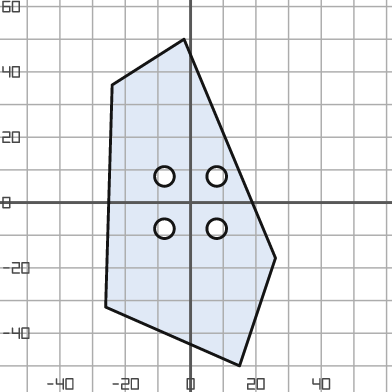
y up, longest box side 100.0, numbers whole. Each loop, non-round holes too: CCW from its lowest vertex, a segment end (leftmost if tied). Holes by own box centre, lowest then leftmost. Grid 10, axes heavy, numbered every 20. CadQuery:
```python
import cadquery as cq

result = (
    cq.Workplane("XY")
    .moveTo(15.0, -50.0)
    .lineTo(26.0, -17.0)
    .lineTo(-2.0, 50.0)
    .lineTo(-24.0, 36.0)
    .lineTo(-26.0, -32.0)
    .close()
    .moveTo(-8.0, -8.0)
    .circle(3.0)
    .moveTo(8.0, -8.0)
    .circle(3.0)
    .moveTo(-8.0, 8.0)
    .circle(3.0)
    .moveTo(8.0, 8.0)
    .circle(3.0)
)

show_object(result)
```